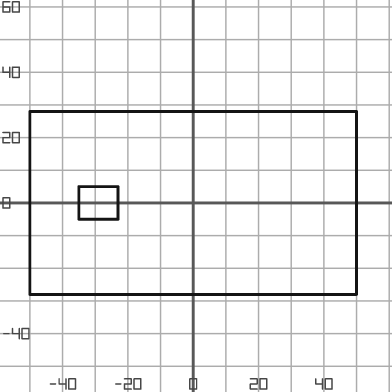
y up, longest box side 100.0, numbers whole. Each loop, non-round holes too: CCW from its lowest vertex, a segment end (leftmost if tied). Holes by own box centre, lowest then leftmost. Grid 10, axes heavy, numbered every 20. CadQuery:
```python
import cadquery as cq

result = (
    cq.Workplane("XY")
    .moveTo(-50.0, -28.0)
    .lineTo(50.0, -28.0)
    .lineTo(50.0, 28.0)
    .lineTo(-50.0, 28.0)
    .close()
    .moveTo(-35.0, -5.0)
    .lineTo(-23.0, -5.0)
    .lineTo(-23.0, 5.0)
    .lineTo(-35.0, 5.0)
    .close()
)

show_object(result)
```